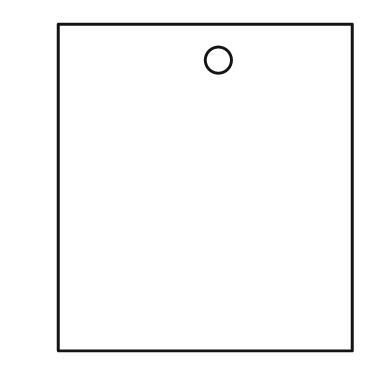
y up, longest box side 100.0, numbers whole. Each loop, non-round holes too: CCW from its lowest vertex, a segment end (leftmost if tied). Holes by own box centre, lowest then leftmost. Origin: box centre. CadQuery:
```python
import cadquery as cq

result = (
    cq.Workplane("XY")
    .moveTo(-45.0, -50.0)
    .lineTo(45.0, -50.0)
    .lineTo(45.0, 50.0)
    .lineTo(-45.0, 50.0)
    .close()
    .moveTo(4.0, 39.0)
    .circle(4.0)
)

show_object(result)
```